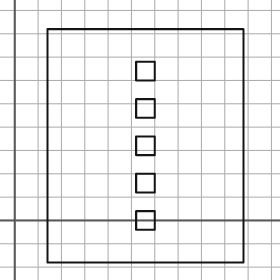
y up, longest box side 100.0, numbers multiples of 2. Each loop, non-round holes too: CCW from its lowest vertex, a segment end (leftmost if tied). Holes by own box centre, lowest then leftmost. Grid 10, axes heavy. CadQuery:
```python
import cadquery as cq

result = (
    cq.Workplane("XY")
    .moveTo(14.0, -18.0)
    .lineTo(98.0, -18.0)
    .lineTo(98.0, 82.0)
    .lineTo(14.0, 82.0)
    .close()
    .moveTo(52.0, -4.0)
    .lineTo(60.0, -4.0)
    .lineTo(60.0, 4.0)
    .lineTo(52.0, 4.0)
    .close()
    .moveTo(52.0, 12.0)
    .lineTo(60.0, 12.0)
    .lineTo(60.0, 20.0)
    .lineTo(52.0, 20.0)
    .close()
    .moveTo(52.0, 28.0)
    .lineTo(60.0, 28.0)
    .lineTo(60.0, 36.0)
    .lineTo(52.0, 36.0)
    .close()
    .moveTo(52.0, 44.0)
    .lineTo(60.0, 44.0)
    .lineTo(60.0, 52.0)
    .lineTo(52.0, 52.0)
    .close()
    .moveTo(52.0, 60.0)
    .lineTo(60.0, 60.0)
    .lineTo(60.0, 68.0)
    .lineTo(52.0, 68.0)
    .close()
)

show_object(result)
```